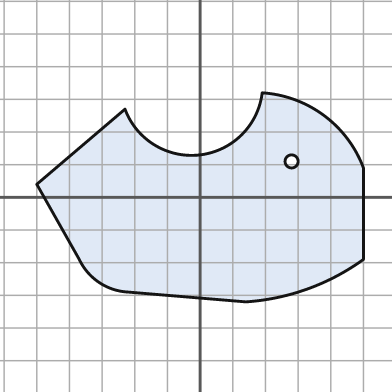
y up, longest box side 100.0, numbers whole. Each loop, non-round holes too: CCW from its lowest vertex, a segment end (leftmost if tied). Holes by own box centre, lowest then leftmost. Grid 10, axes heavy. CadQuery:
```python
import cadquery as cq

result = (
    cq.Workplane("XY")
    .moveTo(14.0, -32.0)
    .threePointArc((33.0, -28.0), (50.0, -19.0))
    .lineTo(50.0, 9.0)
    .threePointArc((38.0, 25.0), (19.0, 32.0))
    .threePointArc((0.0, 13.0), (-23.0, 27.0))
    .lineTo(-50.0, 4.0)
    .lineTo(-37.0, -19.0)
    .threePointArc((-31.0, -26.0), (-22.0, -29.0))
    .close()
    .moveTo(28.0, 11.0)
    .circle(2.0)
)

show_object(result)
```